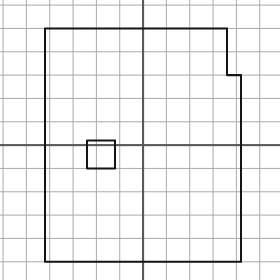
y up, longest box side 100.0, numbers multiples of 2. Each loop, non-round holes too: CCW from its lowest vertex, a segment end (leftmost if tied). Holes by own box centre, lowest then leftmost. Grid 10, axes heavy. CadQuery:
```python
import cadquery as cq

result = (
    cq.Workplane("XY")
    .moveTo(-42.0, -50.0)
    .lineTo(42.0, -50.0)
    .lineTo(42.0, 30.0)
    .lineTo(36.0, 30.0)
    .lineTo(36.0, 50.0)
    .lineTo(-42.0, 50.0)
    .close()
    .moveTo(-24.0, -10.0)
    .lineTo(-12.0, -10.0)
    .lineTo(-12.0, 2.0)
    .lineTo(-24.0, 2.0)
    .close()
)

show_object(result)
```